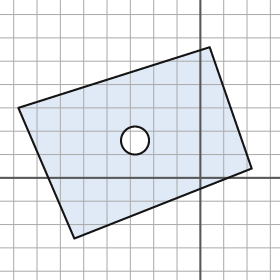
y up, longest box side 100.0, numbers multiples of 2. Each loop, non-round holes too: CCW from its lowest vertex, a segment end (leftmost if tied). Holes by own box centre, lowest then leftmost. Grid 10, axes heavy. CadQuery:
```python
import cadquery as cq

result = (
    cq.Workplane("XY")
    .moveTo(-54.0, -26.0)
    .lineTo(22.0, 4.0)
    .lineTo(4.0, 56.0)
    .lineTo(-78.0, 30.0)
    .close()
    .moveTo(-28.0, 16.0)
    .circle(6.0)
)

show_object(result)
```